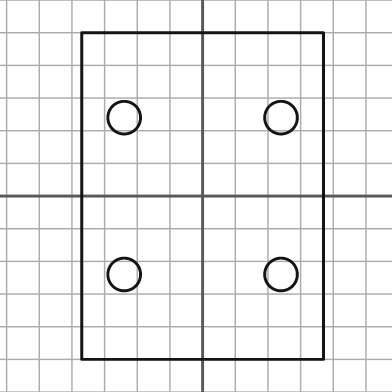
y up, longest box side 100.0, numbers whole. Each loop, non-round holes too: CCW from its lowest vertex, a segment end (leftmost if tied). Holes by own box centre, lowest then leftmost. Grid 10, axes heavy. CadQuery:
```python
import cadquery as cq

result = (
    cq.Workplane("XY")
    .moveTo(-37.0, -50.0)
    .lineTo(37.0, -50.0)
    .lineTo(37.0, 50.0)
    .lineTo(-37.0, 50.0)
    .close()
    .moveTo(-24.0, -24.0)
    .circle(5.0)
    .moveTo(24.0, -24.0)
    .circle(5.0)
    .moveTo(-24.0, 24.0)
    .circle(5.0)
    .moveTo(24.0, 24.0)
    .circle(5.0)
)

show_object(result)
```